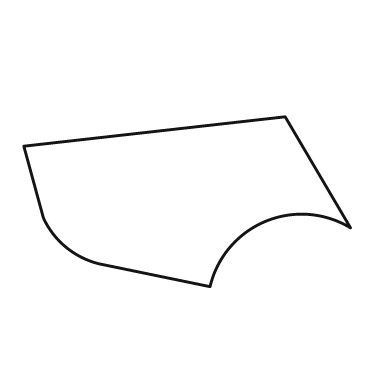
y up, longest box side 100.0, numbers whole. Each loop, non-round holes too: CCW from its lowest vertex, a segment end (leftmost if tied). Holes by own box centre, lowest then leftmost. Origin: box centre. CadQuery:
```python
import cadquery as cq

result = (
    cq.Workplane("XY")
    .moveTo(7.0, -26.0)
    .threePointArc((24.0, -6.0), (50.0, -8.0))
    .lineTo(30.0, 26.0)
    .lineTo(-50.0, 17.0)
    .lineTo(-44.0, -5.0)
    .threePointArc((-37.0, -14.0), (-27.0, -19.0))
    .close()
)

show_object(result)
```